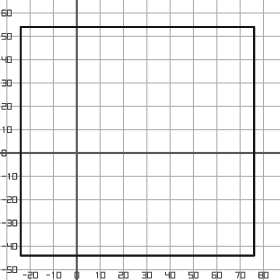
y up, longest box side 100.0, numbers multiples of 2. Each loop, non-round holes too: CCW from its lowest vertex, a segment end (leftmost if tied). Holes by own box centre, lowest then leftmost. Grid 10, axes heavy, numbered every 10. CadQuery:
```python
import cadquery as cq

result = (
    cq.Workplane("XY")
    .moveTo(-24.0, -44.0)
    .lineTo(76.0, -44.0)
    .lineTo(76.0, 54.0)
    .lineTo(-24.0, 54.0)
    .close()
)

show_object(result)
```